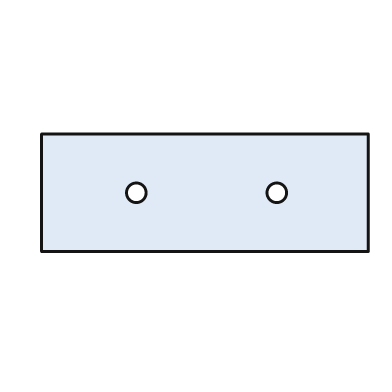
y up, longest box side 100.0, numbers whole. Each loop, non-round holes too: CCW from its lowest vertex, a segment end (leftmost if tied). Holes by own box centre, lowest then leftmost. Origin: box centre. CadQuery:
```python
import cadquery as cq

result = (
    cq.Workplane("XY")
    .moveTo(-50.0, -18.0)
    .lineTo(50.0, -18.0)
    .lineTo(50.0, 18.0)
    .lineTo(-50.0, 18.0)
    .close()
    .moveTo(-21.0, 0.0)
    .circle(3.0)
    .moveTo(22.0, 0.0)
    .circle(3.0)
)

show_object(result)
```